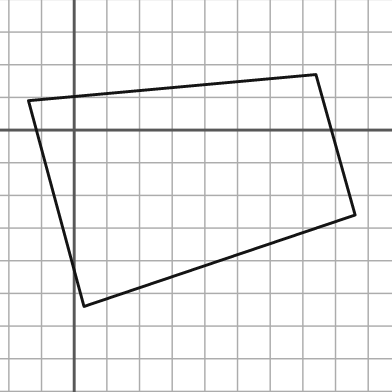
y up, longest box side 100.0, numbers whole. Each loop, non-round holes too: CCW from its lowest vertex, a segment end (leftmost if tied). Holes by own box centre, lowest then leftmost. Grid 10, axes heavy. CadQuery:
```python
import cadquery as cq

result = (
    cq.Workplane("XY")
    .moveTo(3.0, -54.0)
    .lineTo(86.0, -26.0)
    .lineTo(74.0, 17.0)
    .lineTo(-14.0, 9.0)
    .close()
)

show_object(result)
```